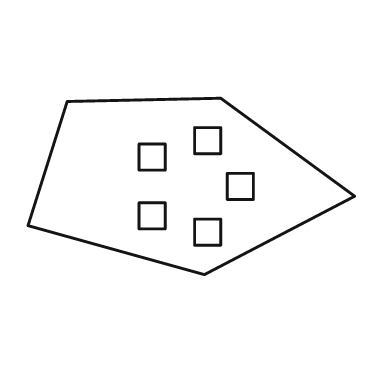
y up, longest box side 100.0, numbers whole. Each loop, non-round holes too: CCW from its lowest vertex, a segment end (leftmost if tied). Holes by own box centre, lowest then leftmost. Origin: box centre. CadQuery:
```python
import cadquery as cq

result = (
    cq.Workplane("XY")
    .moveTo(4.0, -27.0)
    .lineTo(50.0, -3.0)
    .lineTo(9.0, 27.0)
    .lineTo(-38.0, 26.0)
    .lineTo(-50.0, -12.0)
    .close()
    .moveTo(1.0, -18.0)
    .lineTo(9.0, -18.0)
    .lineTo(9.0, -10.0)
    .lineTo(1.0, -10.0)
    .close()
    .moveTo(-16.0, -13.0)
    .lineTo(-8.0, -13.0)
    .lineTo(-8.0, -5.0)
    .lineTo(-16.0, -5.0)
    .close()
    .moveTo(11.0, -4.0)
    .lineTo(19.0, -4.0)
    .lineTo(19.0, 4.0)
    .lineTo(11.0, 4.0)
    .close()
    .moveTo(-16.0, 5.0)
    .lineTo(-8.0, 5.0)
    .lineTo(-8.0, 13.0)
    .lineTo(-16.0, 13.0)
    .close()
    .moveTo(1.0, 10.0)
    .lineTo(9.0, 10.0)
    .lineTo(9.0, 18.0)
    .lineTo(1.0, 18.0)
    .close()
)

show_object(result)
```